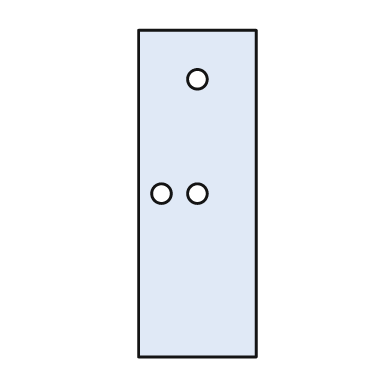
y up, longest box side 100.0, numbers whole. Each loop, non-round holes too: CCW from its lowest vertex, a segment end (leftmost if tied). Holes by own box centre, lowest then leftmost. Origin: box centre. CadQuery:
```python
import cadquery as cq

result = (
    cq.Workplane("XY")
    .moveTo(-18.0, -50.0)
    .lineTo(18.0, -50.0)
    .lineTo(18.0, 50.0)
    .lineTo(-18.0, 50.0)
    .close()
    .moveTo(-11.0, 0.0)
    .circle(3.0)
    .moveTo(0.0, 0.0)
    .circle(3.0)
    .moveTo(0.0, 35.0)
    .circle(3.0)
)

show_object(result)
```